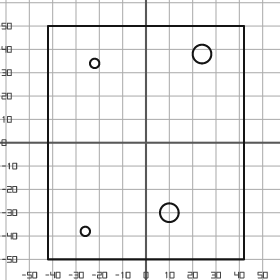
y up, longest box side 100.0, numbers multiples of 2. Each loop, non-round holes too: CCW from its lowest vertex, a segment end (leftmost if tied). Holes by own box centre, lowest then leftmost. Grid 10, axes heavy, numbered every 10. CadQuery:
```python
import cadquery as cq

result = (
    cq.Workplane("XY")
    .moveTo(-42.0, -50.0)
    .lineTo(42.0, -50.0)
    .lineTo(42.0, 50.0)
    .lineTo(-42.0, 50.0)
    .close()
    .moveTo(-26.0, -38.0)
    .circle(2.0)
    .moveTo(10.0, -30.0)
    .circle(4.0)
    .moveTo(-22.0, 34.0)
    .circle(2.0)
    .moveTo(24.0, 38.0)
    .circle(4.0)
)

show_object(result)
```